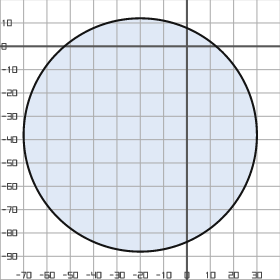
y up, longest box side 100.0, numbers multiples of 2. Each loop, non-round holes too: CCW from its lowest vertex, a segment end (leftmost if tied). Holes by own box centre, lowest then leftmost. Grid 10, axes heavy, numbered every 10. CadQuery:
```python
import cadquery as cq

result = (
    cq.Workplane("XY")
    .moveTo(-20.0, -38.0)
    .circle(50.0)
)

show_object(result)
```